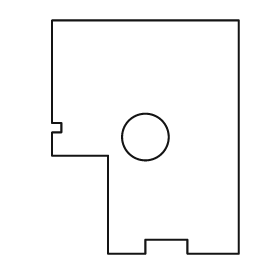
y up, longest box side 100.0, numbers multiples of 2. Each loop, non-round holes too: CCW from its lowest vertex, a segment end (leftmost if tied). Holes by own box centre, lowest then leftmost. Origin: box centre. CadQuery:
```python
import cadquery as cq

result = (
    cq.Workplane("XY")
    .moveTo(-16.0, -50.0)
    .lineTo(0.0, -50.0)
    .lineTo(0.0, -44.0)
    .lineTo(18.0, -44.0)
    .lineTo(18.0, -50.0)
    .lineTo(40.0, -50.0)
    .lineTo(40.0, 50.0)
    .lineTo(-40.0, 50.0)
    .lineTo(-40.0, 6.0)
    .lineTo(-36.0, 6.0)
    .lineTo(-36.0, 2.0)
    .lineTo(-40.0, 2.0)
    .lineTo(-40.0, -8.0)
    .lineTo(-16.0, -8.0)
    .close()
    .moveTo(0.0, 0.0)
    .circle(10.0)
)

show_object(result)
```